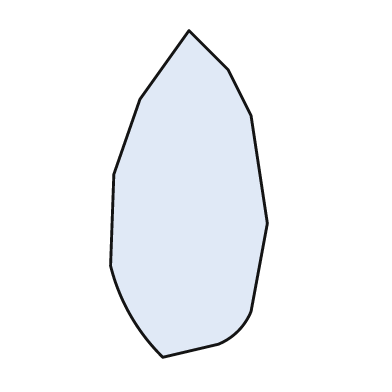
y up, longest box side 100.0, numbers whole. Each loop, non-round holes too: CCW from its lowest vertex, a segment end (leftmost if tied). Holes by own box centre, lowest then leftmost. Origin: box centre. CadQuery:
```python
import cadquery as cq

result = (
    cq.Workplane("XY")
    .moveTo(-8.0, -50.0)
    .lineTo(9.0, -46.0)
    .threePointArc((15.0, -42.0), (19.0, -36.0))
    .lineTo(24.0, -9.0)
    .lineTo(19.0, 24.0)
    .lineTo(12.0, 38.0)
    .lineTo(0.0, 50.0)
    .lineTo(-15.0, 29.0)
    .lineTo(-23.0, 6.0)
    .lineTo(-24.0, -22.0)
    .threePointArc((-18.0, -37.0), (-8.0, -50.0))
    .close()
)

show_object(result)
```